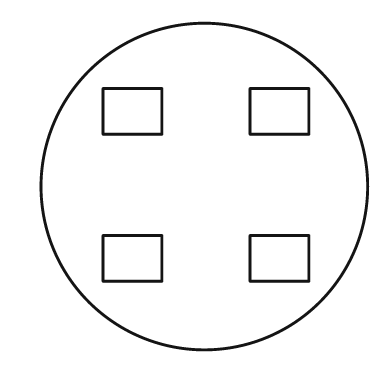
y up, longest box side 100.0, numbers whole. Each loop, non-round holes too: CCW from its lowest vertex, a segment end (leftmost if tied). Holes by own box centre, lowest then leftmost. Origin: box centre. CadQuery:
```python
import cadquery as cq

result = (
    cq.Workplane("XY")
    .moveTo(0.0, 0.0)
    .circle(50.0)
    .moveTo(-31.0, -29.0)
    .lineTo(-13.0, -29.0)
    .lineTo(-13.0, -15.0)
    .lineTo(-31.0, -15.0)
    .close()
    .moveTo(14.0, -29.0)
    .lineTo(32.0, -29.0)
    .lineTo(32.0, -15.0)
    .lineTo(14.0, -15.0)
    .close()
    .moveTo(-31.0, 16.0)
    .lineTo(-13.0, 16.0)
    .lineTo(-13.0, 30.0)
    .lineTo(-31.0, 30.0)
    .close()
    .moveTo(14.0, 16.0)
    .lineTo(32.0, 16.0)
    .lineTo(32.0, 30.0)
    .lineTo(14.0, 30.0)
    .close()
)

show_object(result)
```